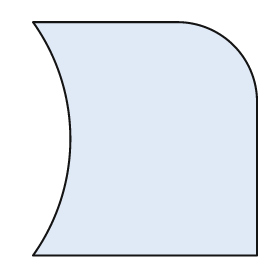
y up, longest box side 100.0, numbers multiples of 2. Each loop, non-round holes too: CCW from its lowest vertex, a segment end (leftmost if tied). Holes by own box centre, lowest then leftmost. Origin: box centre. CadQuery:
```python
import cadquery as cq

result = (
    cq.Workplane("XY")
    .moveTo(-48.0, -50.0)
    .lineTo(48.0, -50.0)
    .lineTo(48.0, 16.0)
    .threePointArc((38.0, 40.0), (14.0, 50.0))
    .lineTo(-48.0, 50.0)
    .threePointArc((-32.0, 0.0), (-48.0, -50.0))
    .close()
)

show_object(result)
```